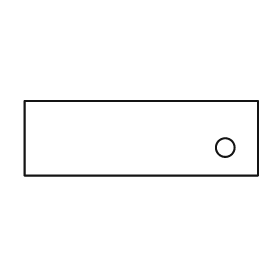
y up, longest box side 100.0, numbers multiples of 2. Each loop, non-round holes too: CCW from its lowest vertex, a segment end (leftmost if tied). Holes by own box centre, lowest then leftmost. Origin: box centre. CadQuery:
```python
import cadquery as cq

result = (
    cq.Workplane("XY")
    .moveTo(-50.0, -16.0)
    .lineTo(50.0, -16.0)
    .lineTo(50.0, 16.0)
    .lineTo(-50.0, 16.0)
    .close()
    .moveTo(36.0, -4.0)
    .circle(4.0)
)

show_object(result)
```